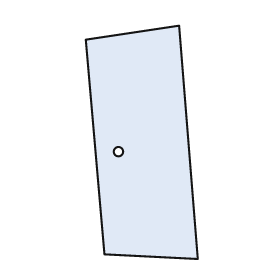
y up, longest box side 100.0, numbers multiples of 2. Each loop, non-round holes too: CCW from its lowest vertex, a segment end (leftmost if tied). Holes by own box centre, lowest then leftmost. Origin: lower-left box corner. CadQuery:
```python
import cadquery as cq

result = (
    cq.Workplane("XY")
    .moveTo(48.0, 0.0)
    .lineTo(40.0, 100.0)
    .lineTo(0.0, 94.0)
    .lineTo(8.0, 2.0)
    .close()
    .moveTo(14.0, 46.0)
    .circle(2.0)
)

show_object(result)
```